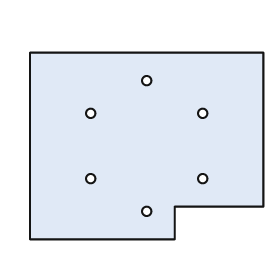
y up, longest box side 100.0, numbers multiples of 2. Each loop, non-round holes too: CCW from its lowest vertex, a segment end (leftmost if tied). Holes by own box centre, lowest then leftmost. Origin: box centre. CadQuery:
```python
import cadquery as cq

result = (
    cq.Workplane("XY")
    .moveTo(-50.0, -40.0)
    .lineTo(12.0, -40.0)
    .lineTo(12.0, -26.0)
    .lineTo(50.0, -26.0)
    .lineTo(50.0, 40.0)
    .lineTo(-50.0, 40.0)
    .close()
    .moveTo(0.0, -28.0)
    .circle(2.0)
    .moveTo(-24.0, -14.0)
    .circle(2.0)
    .moveTo(24.0, -14.0)
    .circle(2.0)
    .moveTo(-24.0, 14.0)
    .circle(2.0)
    .moveTo(24.0, 14.0)
    .circle(2.0)
    .moveTo(0.0, 28.0)
    .circle(2.0)
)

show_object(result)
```